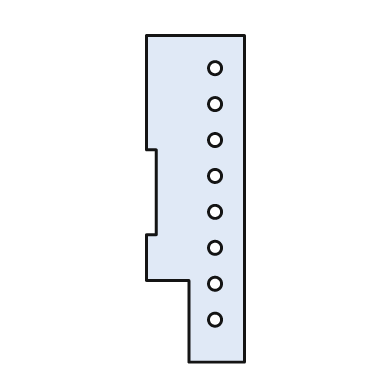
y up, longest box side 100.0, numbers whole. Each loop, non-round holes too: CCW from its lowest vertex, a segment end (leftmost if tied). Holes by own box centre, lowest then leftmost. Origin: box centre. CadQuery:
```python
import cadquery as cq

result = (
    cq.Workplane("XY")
    .moveTo(-2.0, -50.0)
    .lineTo(15.0, -50.0)
    .lineTo(15.0, 50.0)
    .lineTo(-15.0, 50.0)
    .lineTo(-15.0, 15.0)
    .lineTo(-12.0, 15.0)
    .lineTo(-12.0, -11.0)
    .lineTo(-15.0, -11.0)
    .lineTo(-15.0, -25.0)
    .lineTo(-2.0, -25.0)
    .close()
    .moveTo(6.0, -37.0)
    .circle(2.0)
    .moveTo(6.0, -26.0)
    .circle(2.0)
    .moveTo(6.0, -15.0)
    .circle(2.0)
    .moveTo(6.0, -4.0)
    .circle(2.0)
    .moveTo(6.0, 7.0)
    .circle(2.0)
    .moveTo(6.0, 18.0)
    .circle(2.0)
    .moveTo(6.0, 29.0)
    .circle(2.0)
    .moveTo(6.0, 40.0)
    .circle(2.0)
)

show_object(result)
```